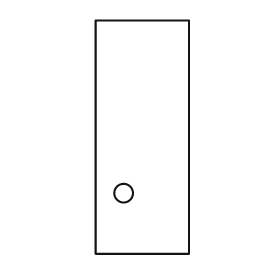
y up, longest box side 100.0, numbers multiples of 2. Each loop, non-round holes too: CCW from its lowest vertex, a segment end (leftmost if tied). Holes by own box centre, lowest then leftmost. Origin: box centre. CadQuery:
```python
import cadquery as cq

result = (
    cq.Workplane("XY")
    .moveTo(-20.0, -50.0)
    .lineTo(20.0, -50.0)
    .lineTo(20.0, 50.0)
    .lineTo(-20.0, 50.0)
    .close()
    .moveTo(-8.0, -24.0)
    .circle(4.0)
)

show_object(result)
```